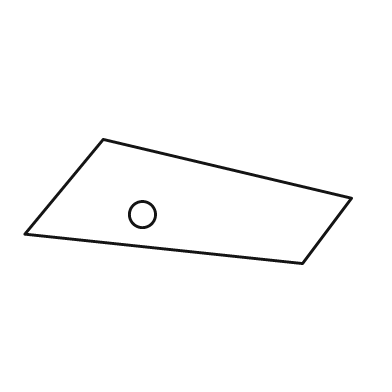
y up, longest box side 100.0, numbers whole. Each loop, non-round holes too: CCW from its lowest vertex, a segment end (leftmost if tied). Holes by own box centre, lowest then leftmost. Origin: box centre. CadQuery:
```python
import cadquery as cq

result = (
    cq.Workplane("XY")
    .moveTo(35.0, -19.0)
    .lineTo(50.0, 1.0)
    .lineTo(-26.0, 19.0)
    .lineTo(-50.0, -10.0)
    .close()
    .moveTo(-14.0, -4.0)
    .circle(4.0)
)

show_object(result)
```